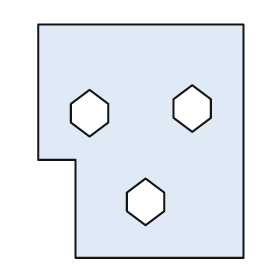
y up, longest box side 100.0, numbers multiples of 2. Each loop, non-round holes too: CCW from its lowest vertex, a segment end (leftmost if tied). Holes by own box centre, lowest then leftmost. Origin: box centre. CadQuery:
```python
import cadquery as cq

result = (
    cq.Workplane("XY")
    .moveTo(-28.0, -50.0)
    .lineTo(44.0, -50.0)
    .lineTo(44.0, 50.0)
    .lineTo(-44.0, 50.0)
    .lineTo(-44.0, -8.0)
    .lineTo(-28.0, -8.0)
    .close()
    .moveTo(2.0, -36.0)
    .lineTo(10.0, -30.0)
    .lineTo(10.0, -22.0)
    .lineTo(2.0, -16.0)
    .lineTo(-6.0, -22.0)
    .lineTo(-6.0, -30.0)
    .close()
    .moveTo(-22.0, 2.0)
    .lineTo(-14.0, 8.0)
    .lineTo(-14.0, 16.0)
    .lineTo(-22.0, 22.0)
    .lineTo(-30.0, 16.0)
    .lineTo(-30.0, 8.0)
    .close()
    .moveTo(22.0, 4.0)
    .lineTo(30.0, 10.0)
    .lineTo(30.0, 18.0)
    .lineTo(22.0, 24.0)
    .lineTo(14.0, 18.0)
    .lineTo(14.0, 10.0)
    .close()
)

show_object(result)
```